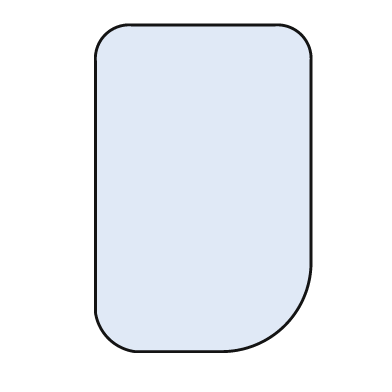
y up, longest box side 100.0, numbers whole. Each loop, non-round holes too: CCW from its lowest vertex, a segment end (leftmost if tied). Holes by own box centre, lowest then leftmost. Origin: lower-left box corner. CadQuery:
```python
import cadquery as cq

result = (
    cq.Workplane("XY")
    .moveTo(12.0, 0.0)
    .lineTo(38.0, 0.0)
    .threePointArc((58.0, 8.0), (66.0, 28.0))
    .lineTo(66.0, 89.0)
    .threePointArc((63.0, 97.0), (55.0, 100.0))
    .lineTo(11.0, 100.0)
    .threePointArc((3.0, 97.0), (0.0, 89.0))
    .lineTo(0.0, 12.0)
    .threePointArc((4.0, 4.0), (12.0, 0.0))
    .close()
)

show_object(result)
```